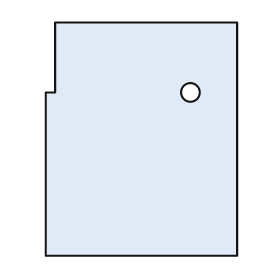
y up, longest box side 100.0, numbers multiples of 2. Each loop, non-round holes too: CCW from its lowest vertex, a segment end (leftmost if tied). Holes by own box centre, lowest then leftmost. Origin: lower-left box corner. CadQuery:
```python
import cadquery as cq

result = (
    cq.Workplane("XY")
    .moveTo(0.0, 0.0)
    .lineTo(82.0, 0.0)
    .lineTo(82.0, 100.0)
    .lineTo(4.0, 100.0)
    .lineTo(4.0, 70.0)
    .lineTo(0.0, 70.0)
    .close()
    .moveTo(62.0, 70.0)
    .circle(4.0)
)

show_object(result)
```